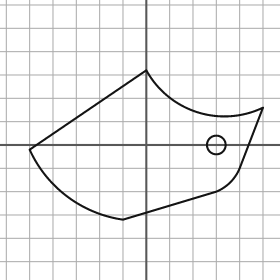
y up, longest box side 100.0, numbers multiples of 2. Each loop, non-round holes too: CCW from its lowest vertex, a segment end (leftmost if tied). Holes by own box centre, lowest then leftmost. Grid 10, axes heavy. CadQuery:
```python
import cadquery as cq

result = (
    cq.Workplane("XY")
    .moveTo(-10.0, -32.0)
    .lineTo(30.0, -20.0)
    .threePointArc((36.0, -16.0), (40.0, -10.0))
    .lineTo(50.0, 16.0)
    .threePointArc((22.0, 14.0), (0.0, 32.0))
    .lineTo(-50.0, -2.0)
    .threePointArc((-34.0, -22.0), (-10.0, -32.0))
    .close()
    .moveTo(30.0, 0.0)
    .circle(4.0)
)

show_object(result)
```